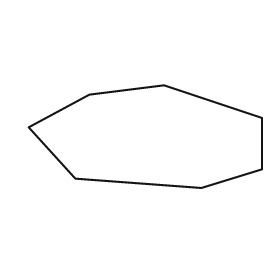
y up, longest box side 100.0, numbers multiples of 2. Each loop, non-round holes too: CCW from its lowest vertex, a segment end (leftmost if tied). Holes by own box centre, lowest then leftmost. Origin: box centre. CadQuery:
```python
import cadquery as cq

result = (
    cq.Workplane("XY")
    .moveTo(24.0, -22.0)
    .lineTo(50.0, -14.0)
    .lineTo(50.0, 8.0)
    .lineTo(8.0, 22.0)
    .lineTo(-24.0, 18.0)
    .lineTo(-50.0, 4.0)
    .lineTo(-30.0, -18.0)
    .close()
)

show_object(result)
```